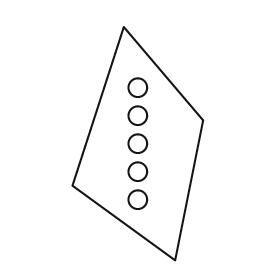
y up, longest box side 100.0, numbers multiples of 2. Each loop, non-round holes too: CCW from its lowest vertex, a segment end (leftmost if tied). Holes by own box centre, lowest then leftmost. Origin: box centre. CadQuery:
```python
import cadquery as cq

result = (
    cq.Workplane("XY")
    .moveTo(16.0, -50.0)
    .lineTo(28.0, 10.0)
    .lineTo(-6.0, 50.0)
    .lineTo(-28.0, -18.0)
    .close()
    .moveTo(0.0, -24.0)
    .circle(4.0)
    .moveTo(0.0, -12.0)
    .circle(4.0)
    .moveTo(0.0, 0.0)
    .circle(4.0)
    .moveTo(0.0, 12.0)
    .circle(4.0)
    .moveTo(0.0, 24.0)
    .circle(4.0)
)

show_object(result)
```